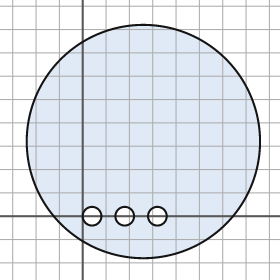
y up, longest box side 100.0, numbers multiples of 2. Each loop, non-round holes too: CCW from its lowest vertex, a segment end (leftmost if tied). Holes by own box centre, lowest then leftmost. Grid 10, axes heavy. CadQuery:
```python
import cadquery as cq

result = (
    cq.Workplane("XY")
    .moveTo(26.0, 32.0)
    .circle(50.0)
    .moveTo(4.0, 0.0)
    .circle(4.0)
    .moveTo(18.0, 0.0)
    .circle(4.0)
    .moveTo(32.0, 0.0)
    .circle(4.0)
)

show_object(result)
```